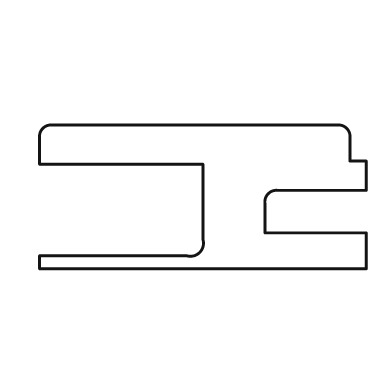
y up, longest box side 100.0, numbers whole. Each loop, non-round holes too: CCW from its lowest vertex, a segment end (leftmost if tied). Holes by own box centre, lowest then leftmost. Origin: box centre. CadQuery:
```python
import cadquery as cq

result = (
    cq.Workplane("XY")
    .moveTo(-50.0, -22.0)
    .lineTo(50.0, -22.0)
    .lineTo(50.0, -11.0)
    .lineTo(19.0, -11.0)
    .lineTo(19.0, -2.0)
    .threePointArc((20.0, 1.0), (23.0, 2.0))
    .lineTo(50.0, 2.0)
    .lineTo(50.0, 11.0)
    .lineTo(45.0, 11.0)
    .lineTo(45.0, 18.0)
    .threePointArc((44.0, 21.0), (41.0, 22.0))
    .lineTo(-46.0, 22.0)
    .threePointArc((-49.0, 21.0), (-50.0, 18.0))
    .lineTo(-50.0, 10.0)
    .lineTo(0.0, 10.0)
    .lineTo(0.0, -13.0)
    .threePointArc((-1.0, -17.0), (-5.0, -18.0))
    .lineTo(-50.0, -18.0)
    .close()
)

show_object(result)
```